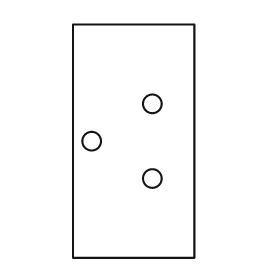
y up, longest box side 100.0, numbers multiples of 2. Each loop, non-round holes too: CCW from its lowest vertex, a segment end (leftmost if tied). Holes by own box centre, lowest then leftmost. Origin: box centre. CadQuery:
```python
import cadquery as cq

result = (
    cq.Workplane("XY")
    .moveTo(-26.0, -50.0)
    .lineTo(26.0, -50.0)
    .lineTo(26.0, 50.0)
    .lineTo(-26.0, 50.0)
    .close()
    .moveTo(8.0, -16.0)
    .circle(4.0)
    .moveTo(-18.0, 0.0)
    .circle(4.0)
    .moveTo(8.0, 16.0)
    .circle(4.0)
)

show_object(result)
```